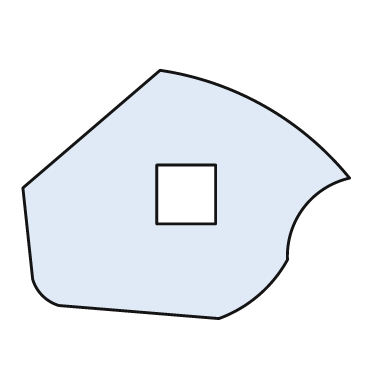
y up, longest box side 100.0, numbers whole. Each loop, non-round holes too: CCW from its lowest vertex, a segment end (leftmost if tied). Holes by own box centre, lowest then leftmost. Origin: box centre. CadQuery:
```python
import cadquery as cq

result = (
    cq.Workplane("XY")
    .moveTo(10.0, -38.0)
    .threePointArc((22.0, -31.0), (31.0, -20.0))
    .threePointArc((36.0, -4.0), (50.0, 5.0))
    .threePointArc((24.0, 27.0), (-8.0, 38.0))
    .lineTo(-50.0, 2.0)
    .lineTo(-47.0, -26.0)
    .threePointArc((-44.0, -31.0), (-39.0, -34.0))
    .close()
    .moveTo(-9.0, -9.0)
    .lineTo(9.0, -9.0)
    .lineTo(9.0, 9.0)
    .lineTo(-9.0, 9.0)
    .close()
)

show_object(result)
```